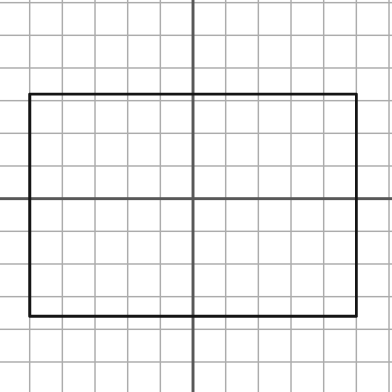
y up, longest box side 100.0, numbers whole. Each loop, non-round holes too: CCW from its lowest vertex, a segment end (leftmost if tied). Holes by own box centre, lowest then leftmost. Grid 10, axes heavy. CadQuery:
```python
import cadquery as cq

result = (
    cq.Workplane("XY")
    .moveTo(-50.0, -36.0)
    .lineTo(50.0, -36.0)
    .lineTo(50.0, 32.0)
    .lineTo(-50.0, 32.0)
    .close()
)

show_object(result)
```